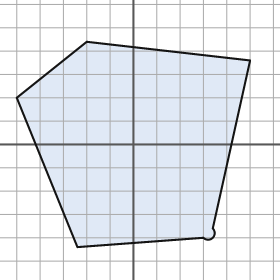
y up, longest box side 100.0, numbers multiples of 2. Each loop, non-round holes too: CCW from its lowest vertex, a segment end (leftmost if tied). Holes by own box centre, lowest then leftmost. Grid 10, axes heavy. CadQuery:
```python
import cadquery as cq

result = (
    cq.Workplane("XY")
    .moveTo(-24.0, -44.0)
    .lineTo(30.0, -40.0)
    .threePointArc((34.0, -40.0), (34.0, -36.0))
    .lineTo(50.0, 36.0)
    .lineTo(-20.0, 44.0)
    .lineTo(-50.0, 20.0)
    .close()
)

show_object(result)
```